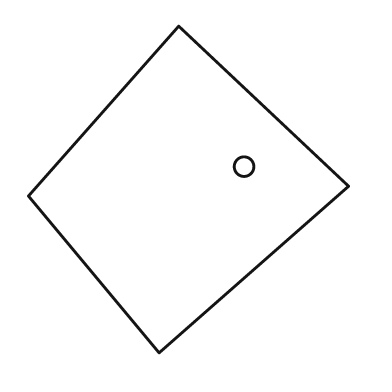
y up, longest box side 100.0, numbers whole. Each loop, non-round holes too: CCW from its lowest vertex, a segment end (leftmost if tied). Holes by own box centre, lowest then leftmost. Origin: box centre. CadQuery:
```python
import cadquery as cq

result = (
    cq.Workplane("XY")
    .moveTo(-9.0, -50.0)
    .lineTo(49.0, 1.0)
    .lineTo(-3.0, 50.0)
    .lineTo(-49.0, -2.0)
    .close()
    .moveTo(17.0, 7.0)
    .circle(3.0)
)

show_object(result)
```